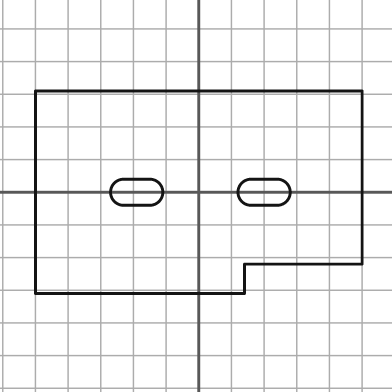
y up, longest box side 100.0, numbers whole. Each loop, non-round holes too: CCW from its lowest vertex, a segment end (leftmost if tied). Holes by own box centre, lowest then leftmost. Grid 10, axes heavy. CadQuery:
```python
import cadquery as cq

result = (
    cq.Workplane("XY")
    .moveTo(-50.0, -31.0)
    .lineTo(14.0, -31.0)
    .lineTo(14.0, -22.0)
    .lineTo(50.0, -22.0)
    .lineTo(50.0, 31.0)
    .lineTo(-50.0, 31.0)
    .close()
    .moveTo(-23.0, -4.0)
    .lineTo(-15.0, -4.0)
    .threePointArc((-11.0, 0.0), (-15.0, 4.0))
    .lineTo(-23.0, 4.0)
    .threePointArc((-27.0, 0.0), (-23.0, -4.0))
    .close()
    .moveTo(16.0, -4.0)
    .lineTo(24.0, -4.0)
    .threePointArc((28.0, 0.0), (24.0, 4.0))
    .lineTo(16.0, 4.0)
    .threePointArc((12.0, 0.0), (16.0, -4.0))
    .close()
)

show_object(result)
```